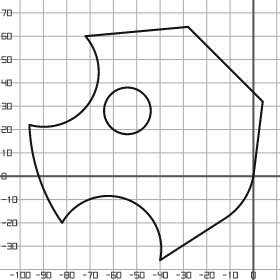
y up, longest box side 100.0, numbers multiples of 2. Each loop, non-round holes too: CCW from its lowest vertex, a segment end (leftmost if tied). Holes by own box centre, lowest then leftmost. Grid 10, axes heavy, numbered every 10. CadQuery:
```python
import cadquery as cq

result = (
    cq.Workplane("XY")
    .moveTo(-40.0, -36.0)
    .lineTo(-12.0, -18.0)
    .threePointArc((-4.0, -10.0), (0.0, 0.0))
    .lineTo(4.0, 32.0)
    .lineTo(-28.0, 64.0)
    .lineTo(-72.0, 60.0)
    .threePointArc((-70.0, 32.0), (-96.0, 22.0))
    .threePointArc((-92.0, 0.0), (-82.0, -20.0))
    .threePointArc((-54.0, -10.0), (-40.0, -36.0))
    .close()
    .moveTo(-54.0, 28.0)
    .circle(10.0)
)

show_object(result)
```